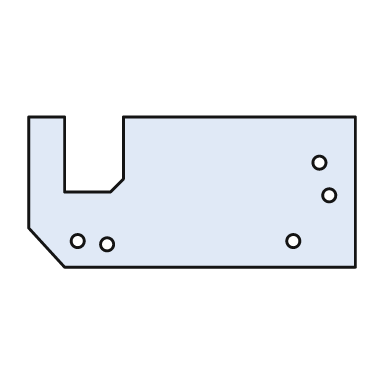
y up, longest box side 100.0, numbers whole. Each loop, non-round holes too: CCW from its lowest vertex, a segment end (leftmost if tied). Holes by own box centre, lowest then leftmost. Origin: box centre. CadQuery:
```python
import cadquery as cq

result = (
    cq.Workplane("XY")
    .moveTo(-39.0, -23.0)
    .lineTo(50.0, -23.0)
    .lineTo(50.0, 23.0)
    .lineTo(-21.0, 23.0)
    .lineTo(-21.0, 4.0)
    .lineTo(-25.0, 0.0)
    .lineTo(-39.0, 0.0)
    .lineTo(-39.0, 23.0)
    .lineTo(-50.0, 23.0)
    .lineTo(-50.0, -11.0)
    .close()
    .moveTo(-26.0, -16.0)
    .circle(2.0)
    .moveTo(-35.0, -15.0)
    .circle(2.0)
    .moveTo(31.0, -15.0)
    .circle(2.0)
    .moveTo(42.0, -1.0)
    .circle(2.0)
    .moveTo(39.0, 9.0)
    .circle(2.0)
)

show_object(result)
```